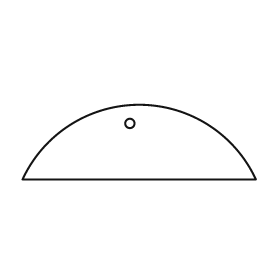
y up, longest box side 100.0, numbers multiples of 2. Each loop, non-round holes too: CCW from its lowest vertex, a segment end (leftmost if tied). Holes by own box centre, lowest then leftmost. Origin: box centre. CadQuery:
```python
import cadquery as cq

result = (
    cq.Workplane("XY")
    .moveTo(-50.0, -16.0)
    .lineTo(50.0, -16.0)
    .threePointArc((0.0, 16.0), (-50.0, -16.0))
    .close()
    .moveTo(-4.0, 8.0)
    .circle(2.0)
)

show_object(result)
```